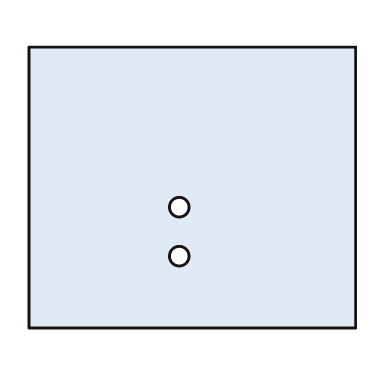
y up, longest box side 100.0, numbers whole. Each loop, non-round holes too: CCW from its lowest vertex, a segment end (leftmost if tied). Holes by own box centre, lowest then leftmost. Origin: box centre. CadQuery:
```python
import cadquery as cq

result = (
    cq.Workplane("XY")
    .moveTo(-50.0, -43.0)
    .lineTo(50.0, -43.0)
    .lineTo(50.0, 43.0)
    .lineTo(-50.0, 43.0)
    .close()
    .moveTo(-4.0, -21.0)
    .circle(3.0)
    .moveTo(-4.0, -6.0)
    .circle(3.0)
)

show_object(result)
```